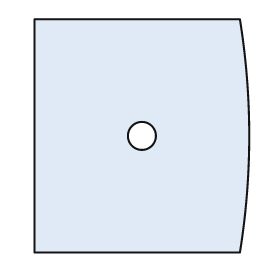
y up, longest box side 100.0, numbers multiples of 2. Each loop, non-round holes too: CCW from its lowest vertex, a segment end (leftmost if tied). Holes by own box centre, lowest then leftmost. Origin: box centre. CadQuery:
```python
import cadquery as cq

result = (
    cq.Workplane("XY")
    .moveTo(-46.0, -50.0)
    .lineTo(42.0, -50.0)
    .threePointArc((46.0, 0.0), (42.0, 50.0))
    .lineTo(-46.0, 50.0)
    .close()
    .moveTo(0.0, 0.0)
    .circle(6.0)
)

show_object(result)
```